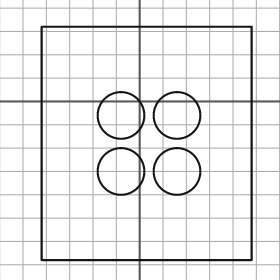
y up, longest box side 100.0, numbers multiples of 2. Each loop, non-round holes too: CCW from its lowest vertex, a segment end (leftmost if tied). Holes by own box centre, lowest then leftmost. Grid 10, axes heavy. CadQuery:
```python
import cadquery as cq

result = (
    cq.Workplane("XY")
    .moveTo(-42.0, -68.0)
    .lineTo(48.0, -68.0)
    .lineTo(48.0, 32.0)
    .lineTo(-42.0, 32.0)
    .close()
    .moveTo(-8.0, -30.0)
    .circle(10.0)
    .moveTo(16.0, -30.0)
    .circle(10.0)
    .moveTo(-8.0, -6.0)
    .circle(10.0)
    .moveTo(16.0, -6.0)
    .circle(10.0)
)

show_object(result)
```